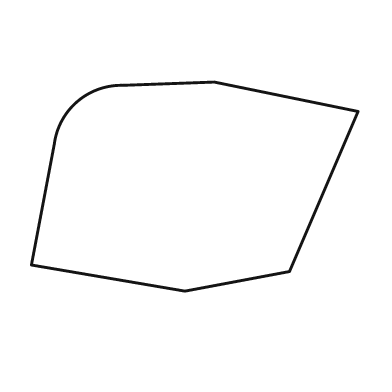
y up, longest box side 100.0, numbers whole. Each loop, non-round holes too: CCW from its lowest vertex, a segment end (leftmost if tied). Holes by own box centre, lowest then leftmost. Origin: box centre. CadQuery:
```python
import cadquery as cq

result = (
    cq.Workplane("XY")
    .moveTo(-3.0, -32.0)
    .lineTo(29.0, -26.0)
    .lineTo(50.0, 23.0)
    .lineTo(6.0, 32.0)
    .lineTo(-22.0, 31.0)
    .threePointArc((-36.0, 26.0), (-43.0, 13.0))
    .lineTo(-50.0, -24.0)
    .close()
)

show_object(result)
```